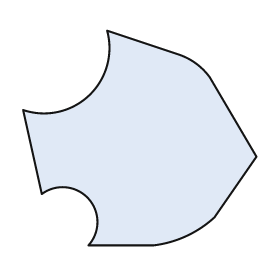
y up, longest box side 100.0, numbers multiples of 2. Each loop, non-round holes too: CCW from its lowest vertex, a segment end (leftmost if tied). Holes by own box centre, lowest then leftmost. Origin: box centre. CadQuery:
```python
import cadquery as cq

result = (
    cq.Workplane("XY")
    .moveTo(-22.0, -46.0)
    .lineTo(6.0, -46.0)
    .threePointArc((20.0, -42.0), (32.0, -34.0))
    .lineTo(50.0, -8.0)
    .lineTo(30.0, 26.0)
    .threePointArc((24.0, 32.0), (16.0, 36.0))
    .lineTo(-14.0, 46.0)
    .threePointArc((-22.0, 18.0), (-50.0, 12.0))
    .lineTo(-42.0, -24.0)
    .threePointArc((-22.0, -26.0), (-22.0, -46.0))
    .close()
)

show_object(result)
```